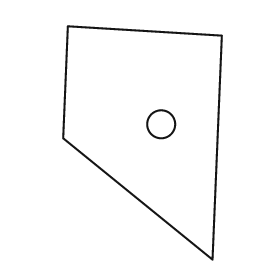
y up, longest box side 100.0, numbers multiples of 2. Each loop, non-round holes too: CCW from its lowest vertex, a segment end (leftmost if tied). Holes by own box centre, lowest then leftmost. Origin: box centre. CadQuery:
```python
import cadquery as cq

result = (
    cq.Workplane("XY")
    .moveTo(30.0, -50.0)
    .lineTo(34.0, 46.0)
    .lineTo(-32.0, 50.0)
    .lineTo(-34.0, 2.0)
    .close()
    .moveTo(8.0, 8.0)
    .circle(6.0)
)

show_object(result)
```